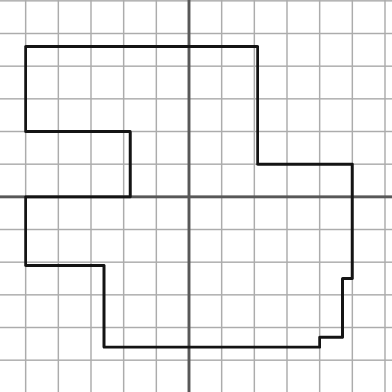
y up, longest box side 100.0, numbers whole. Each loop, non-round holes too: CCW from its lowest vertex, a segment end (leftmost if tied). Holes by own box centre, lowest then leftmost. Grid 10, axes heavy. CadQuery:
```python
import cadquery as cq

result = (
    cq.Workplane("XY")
    .moveTo(-26.0, -46.0)
    .lineTo(40.0, -46.0)
    .lineTo(40.0, -43.0)
    .lineTo(47.0, -43.0)
    .lineTo(47.0, -25.0)
    .lineTo(50.0, -25.0)
    .lineTo(50.0, 10.0)
    .lineTo(21.0, 10.0)
    .lineTo(21.0, 46.0)
    .lineTo(-50.0, 46.0)
    .lineTo(-50.0, 20.0)
    .lineTo(-18.0, 20.0)
    .lineTo(-18.0, 0.0)
    .lineTo(-50.0, 0.0)
    .lineTo(-50.0, -21.0)
    .lineTo(-26.0, -21.0)
    .close()
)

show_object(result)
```